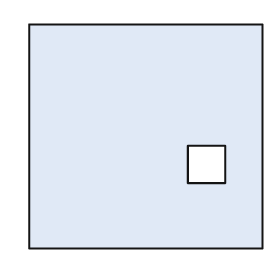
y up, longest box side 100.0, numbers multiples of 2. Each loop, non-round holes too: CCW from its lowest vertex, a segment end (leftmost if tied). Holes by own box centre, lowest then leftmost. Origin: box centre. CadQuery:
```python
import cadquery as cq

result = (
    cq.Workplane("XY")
    .moveTo(-50.0, -48.0)
    .lineTo(50.0, -48.0)
    .lineTo(50.0, 48.0)
    .lineTo(-50.0, 48.0)
    .close()
    .moveTo(18.0, -20.0)
    .lineTo(34.0, -20.0)
    .lineTo(34.0, -4.0)
    .lineTo(18.0, -4.0)
    .close()
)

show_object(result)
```